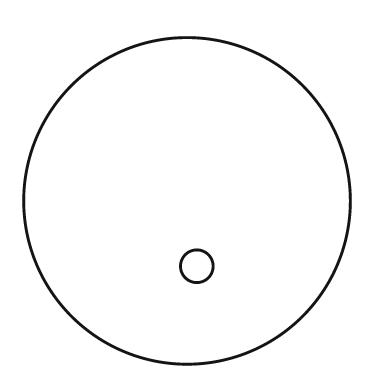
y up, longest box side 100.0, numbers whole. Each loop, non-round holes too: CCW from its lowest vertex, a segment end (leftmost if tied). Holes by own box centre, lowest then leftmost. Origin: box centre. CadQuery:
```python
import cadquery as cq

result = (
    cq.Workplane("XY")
    .moveTo(0.0, 0.0)
    .circle(50.0)
    .moveTo(3.0, -20.0)
    .circle(5.0)
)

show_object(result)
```